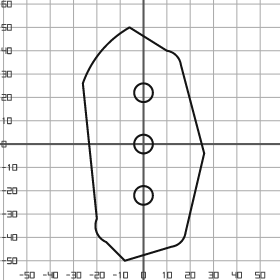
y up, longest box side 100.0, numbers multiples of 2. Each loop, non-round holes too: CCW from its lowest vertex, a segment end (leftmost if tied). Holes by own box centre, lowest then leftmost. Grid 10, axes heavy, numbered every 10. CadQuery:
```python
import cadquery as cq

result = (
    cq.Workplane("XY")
    .moveTo(-8.0, -50.0)
    .lineTo(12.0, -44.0)
    .threePointArc((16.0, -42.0), (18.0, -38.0))
    .lineTo(26.0, -4.0)
    .lineTo(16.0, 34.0)
    .threePointArc((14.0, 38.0), (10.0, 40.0))
    .lineTo(-6.0, 50.0)
    .threePointArc((-18.0, 40.0), (-26.0, 26.0))
    .lineTo(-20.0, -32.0)
    .threePointArc((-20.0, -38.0), (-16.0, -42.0))
    .close()
    .moveTo(0.0, -22.0)
    .circle(4.0)
    .moveTo(0.0, 0.0)
    .circle(4.0)
    .moveTo(0.0, 22.0)
    .circle(4.0)
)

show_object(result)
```